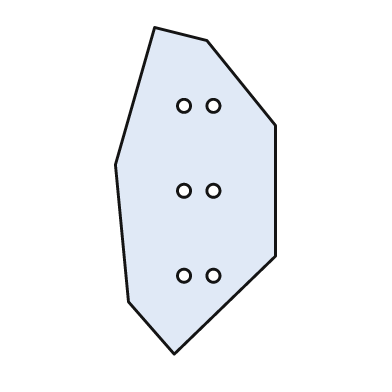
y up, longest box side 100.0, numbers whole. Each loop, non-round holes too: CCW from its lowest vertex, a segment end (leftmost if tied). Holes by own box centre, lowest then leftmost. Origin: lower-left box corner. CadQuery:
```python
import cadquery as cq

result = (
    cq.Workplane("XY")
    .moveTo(18.0, 0.0)
    .lineTo(49.0, 30.0)
    .lineTo(49.0, 70.0)
    .lineTo(28.0, 96.0)
    .lineTo(12.0, 100.0)
    .lineTo(0.0, 58.0)
    .lineTo(4.0, 16.0)
    .close()
    .moveTo(21.0, 24.0)
    .circle(2.0)
    .moveTo(30.0, 24.0)
    .circle(2.0)
    .moveTo(21.0, 50.0)
    .circle(2.0)
    .moveTo(30.0, 50.0)
    .circle(2.0)
    .moveTo(21.0, 76.0)
    .circle(2.0)
    .moveTo(30.0, 76.0)
    .circle(2.0)
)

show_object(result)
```